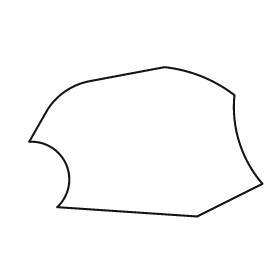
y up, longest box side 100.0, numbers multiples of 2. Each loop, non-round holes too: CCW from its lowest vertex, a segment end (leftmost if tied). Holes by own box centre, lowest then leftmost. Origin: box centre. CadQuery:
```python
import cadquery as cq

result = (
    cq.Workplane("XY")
    .moveTo(22.0, -32.0)
    .lineTo(50.0, -18.0)
    .threePointArc((40.0, 0.0), (38.0, 20.0))
    .threePointArc((24.0, 28.0), (8.0, 32.0))
    .lineTo(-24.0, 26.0)
    .threePointArc((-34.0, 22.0), (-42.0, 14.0))
    .lineTo(-50.0, 0.0)
    .threePointArc((-34.0, -10.0), (-38.0, -28.0))
    .close()
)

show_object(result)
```